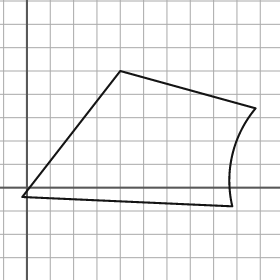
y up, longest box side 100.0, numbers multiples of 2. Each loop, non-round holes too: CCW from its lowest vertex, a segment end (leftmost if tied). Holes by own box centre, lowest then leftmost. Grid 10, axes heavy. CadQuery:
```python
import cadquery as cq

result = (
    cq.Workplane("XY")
    .moveTo(88.0, -8.0)
    .threePointArc((88.0, 14.0), (98.0, 34.0))
    .lineTo(40.0, 50.0)
    .lineTo(-2.0, -4.0)
    .close()
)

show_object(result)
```